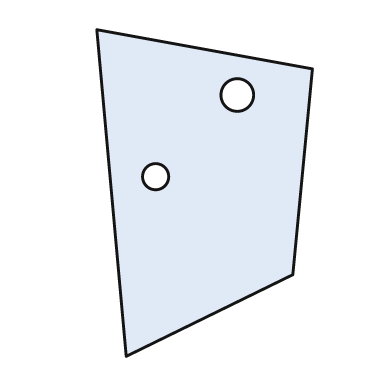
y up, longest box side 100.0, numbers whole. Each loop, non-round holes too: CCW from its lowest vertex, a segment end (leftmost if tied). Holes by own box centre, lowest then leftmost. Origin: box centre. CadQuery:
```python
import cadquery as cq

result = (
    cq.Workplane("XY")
    .moveTo(-24.0, -50.0)
    .lineTo(27.0, -25.0)
    .lineTo(33.0, 38.0)
    .lineTo(-33.0, 50.0)
    .close()
    .moveTo(-15.0, 5.0)
    .circle(4.0)
    .moveTo(10.0, 30.0)
    .circle(5.0)
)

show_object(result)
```